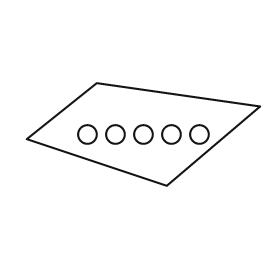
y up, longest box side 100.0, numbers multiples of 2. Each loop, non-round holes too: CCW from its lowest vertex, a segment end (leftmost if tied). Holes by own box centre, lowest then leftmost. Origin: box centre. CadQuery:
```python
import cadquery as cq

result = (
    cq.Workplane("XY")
    .moveTo(10.0, -22.0)
    .lineTo(50.0, 12.0)
    .lineTo(-20.0, 22.0)
    .lineTo(-50.0, -2.0)
    .close()
    .moveTo(-24.0, 0.0)
    .circle(4.0)
    .moveTo(-12.0, 0.0)
    .circle(4.0)
    .moveTo(0.0, 0.0)
    .circle(4.0)
    .moveTo(12.0, 0.0)
    .circle(4.0)
    .moveTo(24.0, 0.0)
    .circle(4.0)
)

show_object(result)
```